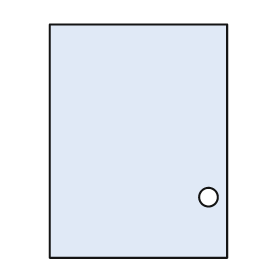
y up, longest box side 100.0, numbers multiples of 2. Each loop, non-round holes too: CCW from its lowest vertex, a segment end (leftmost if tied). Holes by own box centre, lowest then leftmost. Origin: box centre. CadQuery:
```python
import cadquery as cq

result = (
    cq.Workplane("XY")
    .moveTo(-38.0, -50.0)
    .lineTo(38.0, -50.0)
    .lineTo(38.0, 50.0)
    .lineTo(-38.0, 50.0)
    .close()
    .moveTo(30.0, -24.0)
    .circle(4.0)
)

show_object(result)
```